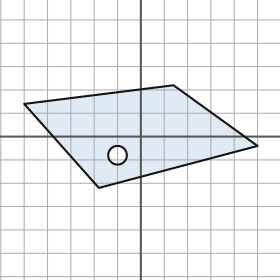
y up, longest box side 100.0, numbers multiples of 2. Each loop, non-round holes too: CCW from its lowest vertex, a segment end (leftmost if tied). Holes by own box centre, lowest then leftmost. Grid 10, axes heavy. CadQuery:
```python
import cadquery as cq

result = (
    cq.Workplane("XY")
    .moveTo(-18.0, -22.0)
    .lineTo(50.0, -4.0)
    .lineTo(14.0, 22.0)
    .lineTo(-50.0, 14.0)
    .close()
    .moveTo(-10.0, -8.0)
    .circle(4.0)
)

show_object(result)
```